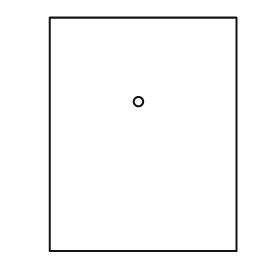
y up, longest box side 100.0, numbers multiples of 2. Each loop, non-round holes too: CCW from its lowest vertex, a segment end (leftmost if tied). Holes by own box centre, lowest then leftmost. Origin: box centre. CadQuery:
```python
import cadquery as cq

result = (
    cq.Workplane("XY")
    .moveTo(-40.0, -50.0)
    .lineTo(40.0, -50.0)
    .lineTo(40.0, 50.0)
    .lineTo(-40.0, 50.0)
    .close()
    .moveTo(-2.0, 14.0)
    .circle(2.0)
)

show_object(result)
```